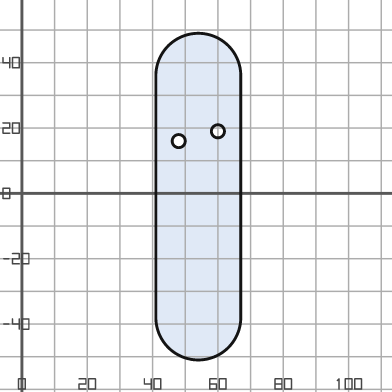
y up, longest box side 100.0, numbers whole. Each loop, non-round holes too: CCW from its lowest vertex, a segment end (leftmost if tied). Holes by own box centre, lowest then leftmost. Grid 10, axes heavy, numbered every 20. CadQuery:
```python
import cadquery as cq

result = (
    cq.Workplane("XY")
    .moveTo(41.0, -38.0)
    .threePointArc((54.0, -51.0), (67.0, -38.0))
    .lineTo(67.0, 36.0)
    .threePointArc((54.0, 49.0), (41.0, 36.0))
    .close()
    .moveTo(48.0, 16.0)
    .circle(2.0)
    .moveTo(60.0, 19.0)
    .circle(2.0)
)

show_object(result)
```